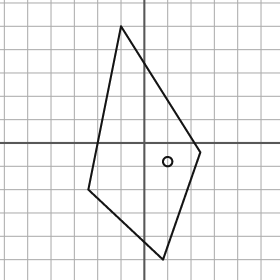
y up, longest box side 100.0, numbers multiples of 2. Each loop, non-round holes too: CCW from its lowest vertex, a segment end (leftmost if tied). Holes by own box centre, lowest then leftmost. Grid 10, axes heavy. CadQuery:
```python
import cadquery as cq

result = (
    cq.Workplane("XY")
    .moveTo(8.0, -50.0)
    .lineTo(24.0, -4.0)
    .lineTo(-10.0, 50.0)
    .lineTo(-24.0, -20.0)
    .close()
    .moveTo(10.0, -8.0)
    .circle(2.0)
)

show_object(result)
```